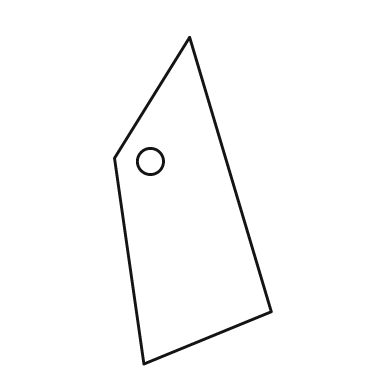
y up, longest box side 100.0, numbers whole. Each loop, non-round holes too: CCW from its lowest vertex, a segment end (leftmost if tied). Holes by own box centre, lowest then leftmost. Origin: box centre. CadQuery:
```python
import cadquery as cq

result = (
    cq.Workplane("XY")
    .moveTo(-15.0, -50.0)
    .lineTo(24.0, -34.0)
    .lineTo(-1.0, 50.0)
    .lineTo(-24.0, 13.0)
    .close()
    .moveTo(-13.0, 12.0)
    .circle(4.0)
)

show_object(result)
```